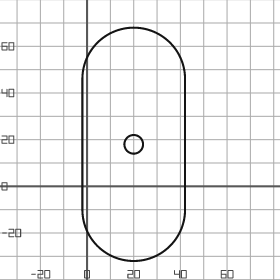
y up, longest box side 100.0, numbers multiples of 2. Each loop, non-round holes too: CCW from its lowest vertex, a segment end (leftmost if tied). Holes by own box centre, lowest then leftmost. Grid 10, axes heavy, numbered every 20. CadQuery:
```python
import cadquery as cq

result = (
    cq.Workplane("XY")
    .moveTo(-2.0, -10.0)
    .threePointArc((20.0, -32.0), (42.0, -10.0))
    .lineTo(42.0, 46.0)
    .threePointArc((20.0, 68.0), (-2.0, 46.0))
    .close()
    .moveTo(20.0, 18.0)
    .circle(4.0)
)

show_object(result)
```